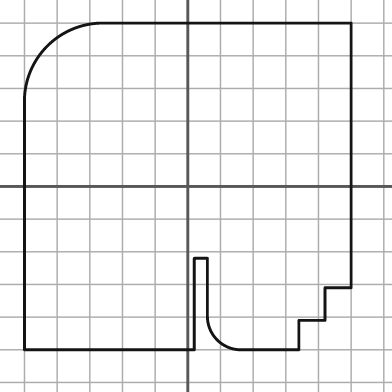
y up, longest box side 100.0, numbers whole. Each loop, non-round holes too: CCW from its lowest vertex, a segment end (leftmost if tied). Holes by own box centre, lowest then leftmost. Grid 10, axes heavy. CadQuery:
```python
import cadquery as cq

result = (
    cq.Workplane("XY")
    .moveTo(-50.0, -50.0)
    .lineTo(2.0, -50.0)
    .lineTo(2.0, -22.0)
    .lineTo(6.0, -22.0)
    .lineTo(6.0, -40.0)
    .threePointArc((9.0, -47.0), (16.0, -50.0))
    .lineTo(34.0, -50.0)
    .lineTo(34.0, -41.0)
    .lineTo(42.0, -41.0)
    .lineTo(42.0, -31.0)
    .lineTo(50.0, -31.0)
    .lineTo(50.0, 50.0)
    .lineTo(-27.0, 50.0)
    .threePointArc((-43.0, 43.0), (-50.0, 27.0))
    .close()
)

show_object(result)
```